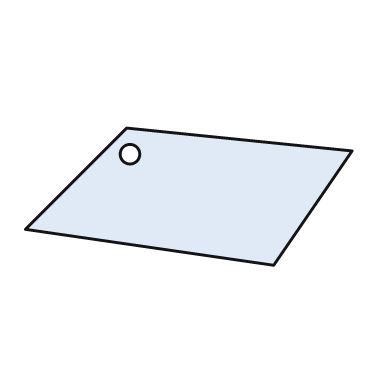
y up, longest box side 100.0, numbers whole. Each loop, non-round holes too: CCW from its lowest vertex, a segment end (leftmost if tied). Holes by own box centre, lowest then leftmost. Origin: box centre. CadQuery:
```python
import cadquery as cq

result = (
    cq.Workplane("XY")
    .moveTo(26.0, -21.0)
    .lineTo(50.0, 14.0)
    .lineTo(-19.0, 21.0)
    .lineTo(-50.0, -10.0)
    .close()
    .moveTo(-18.0, 13.0)
    .circle(3.0)
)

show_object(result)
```